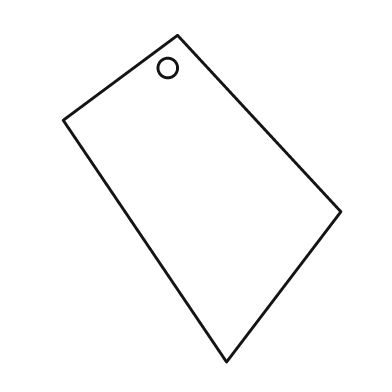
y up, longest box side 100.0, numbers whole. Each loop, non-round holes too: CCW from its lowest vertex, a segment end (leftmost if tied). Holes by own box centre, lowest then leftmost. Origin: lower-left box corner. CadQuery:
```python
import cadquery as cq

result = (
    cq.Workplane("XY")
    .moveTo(50.0, 0.0)
    .lineTo(85.0, 46.0)
    .lineTo(35.0, 100.0)
    .lineTo(0.0, 74.0)
    .close()
    .moveTo(32.0, 90.0)
    .circle(3.0)
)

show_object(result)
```